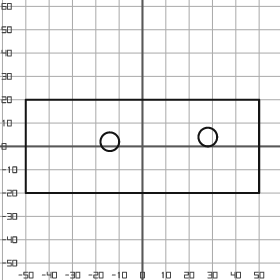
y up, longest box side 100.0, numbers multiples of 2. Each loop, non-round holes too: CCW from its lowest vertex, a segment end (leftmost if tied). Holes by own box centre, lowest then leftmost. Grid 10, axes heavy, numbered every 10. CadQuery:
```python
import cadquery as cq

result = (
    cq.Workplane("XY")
    .moveTo(-50.0, -20.0)
    .lineTo(50.0, -20.0)
    .lineTo(50.0, 20.0)
    .lineTo(-50.0, 20.0)
    .close()
    .moveTo(-14.0, 2.0)
    .circle(4.0)
    .moveTo(28.0, 4.0)
    .circle(4.0)
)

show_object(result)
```